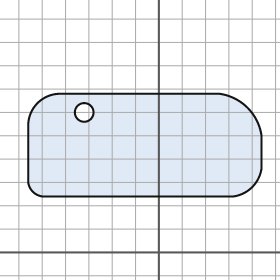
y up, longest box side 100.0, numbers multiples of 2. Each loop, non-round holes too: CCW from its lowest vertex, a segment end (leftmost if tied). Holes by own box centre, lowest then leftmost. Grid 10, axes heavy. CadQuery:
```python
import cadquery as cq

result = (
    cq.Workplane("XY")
    .moveTo(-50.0, 24.0)
    .lineTo(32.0, 24.0)
    .threePointArc((40.0, 28.0), (44.0, 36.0))
    .lineTo(44.0, 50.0)
    .threePointArc((38.0, 62.0), (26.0, 68.0))
    .lineTo(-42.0, 68.0)
    .threePointArc((-52.0, 64.0), (-56.0, 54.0))
    .lineTo(-56.0, 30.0)
    .threePointArc((-54.0, 26.0), (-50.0, 24.0))
    .close()
    .moveTo(-32.0, 60.0)
    .circle(4.0)
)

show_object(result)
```